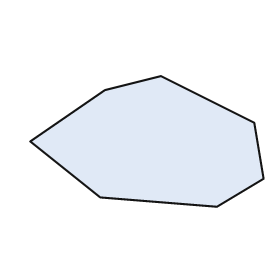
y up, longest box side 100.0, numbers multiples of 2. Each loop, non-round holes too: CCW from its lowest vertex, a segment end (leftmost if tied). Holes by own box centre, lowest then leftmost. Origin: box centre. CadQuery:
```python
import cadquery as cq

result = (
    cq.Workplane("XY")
    .moveTo(30.0, -28.0)
    .lineTo(50.0, -16.0)
    .lineTo(46.0, 8.0)
    .lineTo(6.0, 28.0)
    .lineTo(-18.0, 22.0)
    .lineTo(-50.0, 0.0)
    .lineTo(-20.0, -24.0)
    .close()
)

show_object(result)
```